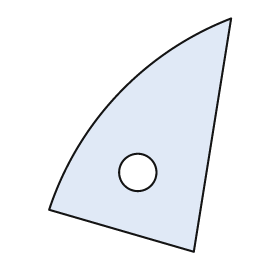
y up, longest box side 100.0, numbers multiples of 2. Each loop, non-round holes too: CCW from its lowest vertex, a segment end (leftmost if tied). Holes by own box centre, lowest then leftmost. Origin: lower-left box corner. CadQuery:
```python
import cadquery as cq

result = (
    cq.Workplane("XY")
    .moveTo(62.0, 0.0)
    .lineTo(78.0, 100.0)
    .threePointArc((30.0, 68.0), (0.0, 18.0))
    .close()
    .moveTo(38.0, 34.0)
    .circle(8.0)
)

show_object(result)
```